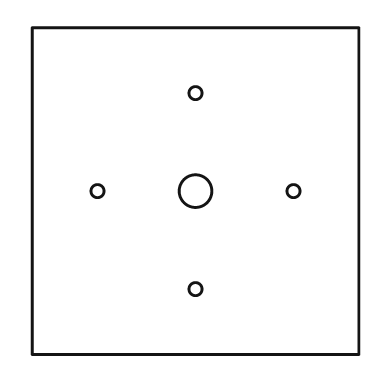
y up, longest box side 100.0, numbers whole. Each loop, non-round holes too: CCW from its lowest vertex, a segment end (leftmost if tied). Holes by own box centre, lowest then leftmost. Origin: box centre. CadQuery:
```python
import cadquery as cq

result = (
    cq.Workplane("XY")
    .moveTo(-50.0, -50.0)
    .lineTo(50.0, -50.0)
    .lineTo(50.0, 50.0)
    .lineTo(-50.0, 50.0)
    .close()
    .moveTo(0.0, -30.0)
    .circle(2.0)
    .moveTo(-30.0, 0.0)
    .circle(2.0)
    .moveTo(0.0, 0.0)
    .circle(5.0)
    .moveTo(30.0, 0.0)
    .circle(2.0)
    .moveTo(0.0, 30.0)
    .circle(2.0)
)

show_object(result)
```